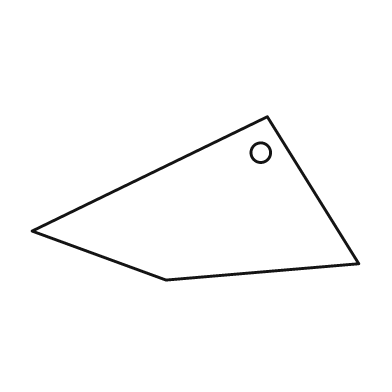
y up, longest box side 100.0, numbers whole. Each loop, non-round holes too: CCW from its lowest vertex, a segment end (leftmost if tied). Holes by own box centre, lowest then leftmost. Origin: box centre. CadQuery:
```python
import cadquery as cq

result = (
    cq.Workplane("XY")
    .moveTo(-9.0, -25.0)
    .lineTo(50.0, -20.0)
    .lineTo(22.0, 25.0)
    .lineTo(-50.0, -10.0)
    .close()
    .moveTo(20.0, 14.0)
    .circle(3.0)
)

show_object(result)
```